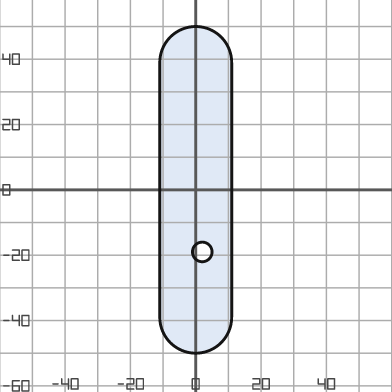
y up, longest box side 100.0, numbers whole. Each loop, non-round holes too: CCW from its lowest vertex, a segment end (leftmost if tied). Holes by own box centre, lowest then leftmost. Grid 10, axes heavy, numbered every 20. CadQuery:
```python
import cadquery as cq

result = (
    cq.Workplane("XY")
    .moveTo(-11.0, -39.0)
    .threePointArc((0.0, -50.0), (11.0, -39.0))
    .lineTo(11.0, 39.0)
    .threePointArc((0.0, 50.0), (-11.0, 39.0))
    .close()
    .moveTo(2.0, -19.0)
    .circle(3.0)
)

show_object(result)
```